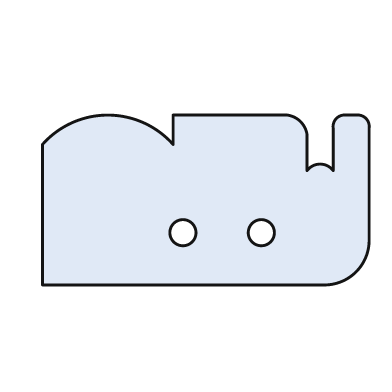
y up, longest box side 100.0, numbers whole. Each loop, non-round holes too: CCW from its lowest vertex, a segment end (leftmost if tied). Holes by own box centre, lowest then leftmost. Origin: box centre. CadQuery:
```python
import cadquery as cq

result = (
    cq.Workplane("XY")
    .moveTo(-50.0, -26.0)
    .lineTo(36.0, -26.0)
    .threePointArc((46.0, -22.0), (50.0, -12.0))
    .lineTo(50.0, 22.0)
    .threePointArc((49.0, 25.0), (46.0, 26.0))
    .lineTo(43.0, 26.0)
    .threePointArc((40.0, 25.0), (39.0, 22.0))
    .lineTo(39.0, 9.0)
    .threePointArc((35.0, 11.0), (31.0, 9.0))
    .lineTo(31.0, 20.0)
    .threePointArc((29.0, 24.0), (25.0, 26.0))
    .lineTo(-10.0, 26.0)
    .lineTo(-10.0, 17.0)
    .threePointArc((-30.0, 26.0), (-50.0, 17.0))
    .close()
    .moveTo(-7.0, -10.0)
    .circle(4.0)
    .moveTo(17.0, -10.0)
    .circle(4.0)
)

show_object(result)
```